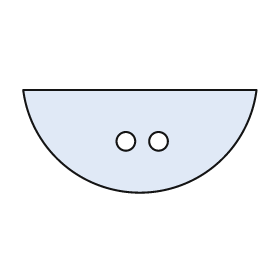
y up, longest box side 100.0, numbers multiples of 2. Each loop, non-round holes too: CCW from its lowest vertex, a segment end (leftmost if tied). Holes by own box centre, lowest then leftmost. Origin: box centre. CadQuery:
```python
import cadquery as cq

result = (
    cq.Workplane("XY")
    .moveTo(-50.0, 22.0)
    .threePointArc((0.0, -22.0), (50.0, 22.0))
    .close()
    .moveTo(-6.0, 0.0)
    .circle(4.0)
    .moveTo(8.0, 0.0)
    .circle(4.0)
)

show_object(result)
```